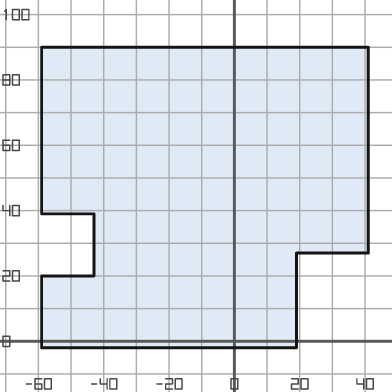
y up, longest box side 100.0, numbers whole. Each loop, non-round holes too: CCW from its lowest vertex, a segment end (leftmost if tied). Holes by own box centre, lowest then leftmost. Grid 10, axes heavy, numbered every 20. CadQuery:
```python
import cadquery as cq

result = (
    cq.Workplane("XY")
    .moveTo(-59.0, -2.0)
    .lineTo(19.0, -2.0)
    .lineTo(19.0, 27.0)
    .lineTo(41.0, 27.0)
    .lineTo(41.0, 90.0)
    .lineTo(-59.0, 90.0)
    .lineTo(-59.0, 39.0)
    .lineTo(-43.0, 39.0)
    .lineTo(-43.0, 20.0)
    .lineTo(-59.0, 20.0)
    .close()
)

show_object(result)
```